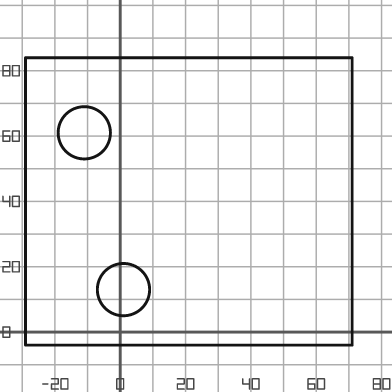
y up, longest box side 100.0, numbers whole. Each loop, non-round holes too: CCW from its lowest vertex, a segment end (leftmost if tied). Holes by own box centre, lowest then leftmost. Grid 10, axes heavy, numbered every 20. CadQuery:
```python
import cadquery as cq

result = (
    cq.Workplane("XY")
    .moveTo(-29.0, -4.0)
    .lineTo(71.0, -4.0)
    .lineTo(71.0, 84.0)
    .lineTo(-29.0, 84.0)
    .close()
    .moveTo(1.0, 13.0)
    .circle(8.0)
    .moveTo(-11.0, 61.0)
    .circle(8.0)
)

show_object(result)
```